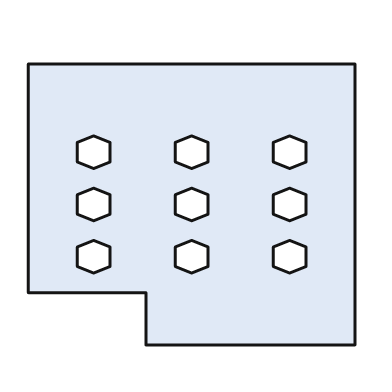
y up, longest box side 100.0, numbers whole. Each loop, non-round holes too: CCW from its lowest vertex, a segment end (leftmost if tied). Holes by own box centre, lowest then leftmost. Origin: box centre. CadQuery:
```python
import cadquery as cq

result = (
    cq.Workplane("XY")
    .moveTo(-14.0, -43.0)
    .lineTo(50.0, -43.0)
    .lineTo(50.0, 43.0)
    .lineTo(-50.0, 43.0)
    .lineTo(-50.0, -27.0)
    .lineTo(-14.0, -27.0)
    .close()
    .moveTo(-30.0, -21.0)
    .lineTo(-25.0, -19.0)
    .lineTo(-25.0, -13.0)
    .lineTo(-30.0, -11.0)
    .lineTo(-35.0, -13.0)
    .lineTo(-35.0, -19.0)
    .close()
    .moveTo(0.0, -21.0)
    .lineTo(5.0, -19.0)
    .lineTo(5.0, -13.0)
    .lineTo(0.0, -11.0)
    .lineTo(-5.0, -13.0)
    .lineTo(-5.0, -19.0)
    .close()
    .moveTo(30.0, -21.0)
    .lineTo(35.0, -19.0)
    .lineTo(35.0, -13.0)
    .lineTo(30.0, -11.0)
    .lineTo(25.0, -13.0)
    .lineTo(25.0, -19.0)
    .close()
    .moveTo(-30.0, -5.0)
    .lineTo(-25.0, -3.0)
    .lineTo(-25.0, 3.0)
    .lineTo(-30.0, 5.0)
    .lineTo(-35.0, 3.0)
    .lineTo(-35.0, -3.0)
    .close()
    .moveTo(0.0, -5.0)
    .lineTo(5.0, -3.0)
    .lineTo(5.0, 3.0)
    .lineTo(0.0, 5.0)
    .lineTo(-5.0, 3.0)
    .lineTo(-5.0, -3.0)
    .close()
    .moveTo(30.0, -5.0)
    .lineTo(35.0, -3.0)
    .lineTo(35.0, 3.0)
    .lineTo(30.0, 5.0)
    .lineTo(25.0, 3.0)
    .lineTo(25.0, -3.0)
    .close()
    .moveTo(-30.0, 11.0)
    .lineTo(-25.0, 13.0)
    .lineTo(-25.0, 19.0)
    .lineTo(-30.0, 21.0)
    .lineTo(-35.0, 19.0)
    .lineTo(-35.0, 13.0)
    .close()
    .moveTo(0.0, 11.0)
    .lineTo(5.0, 13.0)
    .lineTo(5.0, 19.0)
    .lineTo(0.0, 21.0)
    .lineTo(-5.0, 19.0)
    .lineTo(-5.0, 13.0)
    .close()
    .moveTo(30.0, 11.0)
    .lineTo(35.0, 13.0)
    .lineTo(35.0, 19.0)
    .lineTo(30.0, 21.0)
    .lineTo(25.0, 19.0)
    .lineTo(25.0, 13.0)
    .close()
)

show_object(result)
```